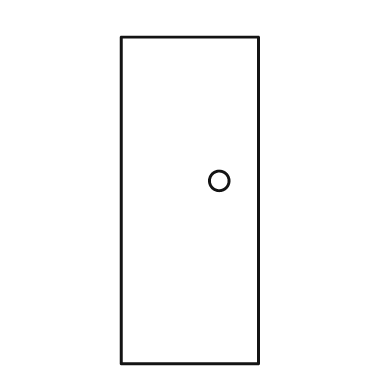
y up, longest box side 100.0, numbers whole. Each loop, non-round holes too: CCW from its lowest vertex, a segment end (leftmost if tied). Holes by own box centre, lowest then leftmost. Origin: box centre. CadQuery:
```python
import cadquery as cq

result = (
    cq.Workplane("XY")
    .moveTo(-21.0, -50.0)
    .lineTo(21.0, -50.0)
    .lineTo(21.0, 50.0)
    .lineTo(-21.0, 50.0)
    .close()
    .moveTo(9.0, 6.0)
    .circle(3.0)
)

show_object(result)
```